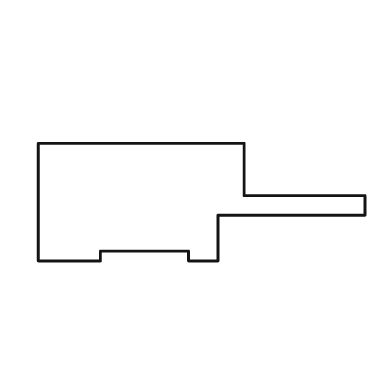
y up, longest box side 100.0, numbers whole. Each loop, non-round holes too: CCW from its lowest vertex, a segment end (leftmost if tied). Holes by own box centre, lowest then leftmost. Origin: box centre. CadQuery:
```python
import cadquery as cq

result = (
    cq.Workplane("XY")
    .moveTo(-50.0, -18.0)
    .lineTo(-31.0, -18.0)
    .lineTo(-31.0, -15.0)
    .lineTo(-4.0, -15.0)
    .lineTo(-4.0, -18.0)
    .lineTo(5.0, -18.0)
    .lineTo(5.0, -4.0)
    .lineTo(50.0, -4.0)
    .lineTo(50.0, 2.0)
    .lineTo(13.0, 2.0)
    .lineTo(13.0, 18.0)
    .lineTo(-50.0, 18.0)
    .close()
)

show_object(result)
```